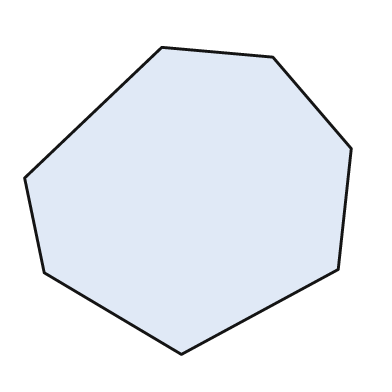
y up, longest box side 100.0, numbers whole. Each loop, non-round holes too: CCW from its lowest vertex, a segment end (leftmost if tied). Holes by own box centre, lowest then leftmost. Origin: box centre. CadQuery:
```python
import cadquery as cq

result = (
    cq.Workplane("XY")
    .moveTo(-2.0, -47.0)
    .lineTo(46.0, -21.0)
    .lineTo(50.0, 16.0)
    .lineTo(26.0, 44.0)
    .lineTo(-8.0, 47.0)
    .lineTo(-50.0, 7.0)
    .lineTo(-44.0, -22.0)
    .close()
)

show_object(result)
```